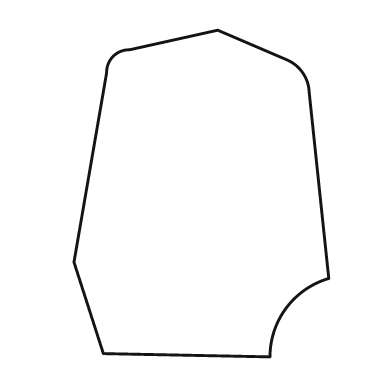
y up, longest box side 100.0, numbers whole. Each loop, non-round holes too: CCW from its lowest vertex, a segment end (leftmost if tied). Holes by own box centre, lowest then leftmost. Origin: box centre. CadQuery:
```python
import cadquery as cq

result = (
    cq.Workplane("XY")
    .moveTo(21.0, -50.0)
    .threePointArc((26.0, -35.0), (39.0, -26.0))
    .lineTo(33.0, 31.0)
    .threePointArc((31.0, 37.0), (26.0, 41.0))
    .lineTo(5.0, 50.0)
    .lineTo(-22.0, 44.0)
    .threePointArc((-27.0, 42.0), (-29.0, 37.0))
    .lineTo(-39.0, -21.0)
    .lineTo(-30.0, -49.0)
    .close()
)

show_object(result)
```